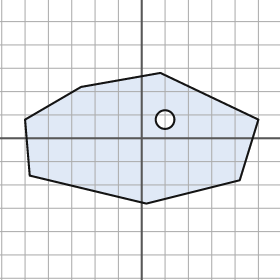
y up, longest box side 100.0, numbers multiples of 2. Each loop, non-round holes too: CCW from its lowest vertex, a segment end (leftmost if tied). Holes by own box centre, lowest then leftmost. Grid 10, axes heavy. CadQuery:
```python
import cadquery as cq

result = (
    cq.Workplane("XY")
    .moveTo(2.0, -28.0)
    .lineTo(42.0, -18.0)
    .lineTo(50.0, 8.0)
    .lineTo(8.0, 28.0)
    .lineTo(-26.0, 22.0)
    .lineTo(-50.0, 8.0)
    .lineTo(-48.0, -16.0)
    .close()
    .moveTo(10.0, 8.0)
    .circle(4.0)
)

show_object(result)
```